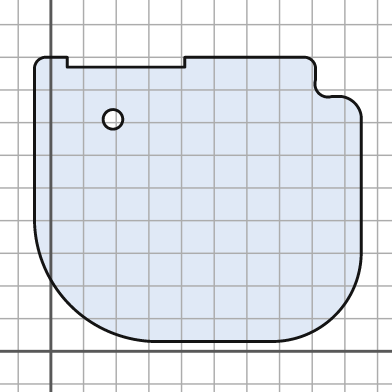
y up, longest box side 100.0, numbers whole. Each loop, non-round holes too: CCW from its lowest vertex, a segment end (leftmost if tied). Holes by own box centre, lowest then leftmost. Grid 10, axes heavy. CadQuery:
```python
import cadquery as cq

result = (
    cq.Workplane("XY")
    .moveTo(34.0, 3.0)
    .lineTo(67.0, 3.0)
    .threePointArc((87.0, 11.0), (95.0, 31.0))
    .lineTo(95.0, 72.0)
    .threePointArc((93.0, 76.0), (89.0, 78.0))
    .lineTo(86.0, 78.0)
    .threePointArc((82.0, 79.0), (81.0, 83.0))
    .lineTo(81.0, 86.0)
    .threePointArc((80.0, 89.0), (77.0, 90.0))
    .lineTo(41.0, 90.0)
    .lineTo(41.0, 87.0)
    .lineTo(5.0, 87.0)
    .lineTo(5.0, 90.0)
    .lineTo(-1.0, 90.0)
    .threePointArc((-4.0, 89.0), (-5.0, 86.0))
    .lineTo(-5.0, 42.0)
    .threePointArc((6.0, 14.0), (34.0, 3.0))
    .close()
    .moveTo(19.0, 71.0)
    .circle(3.0)
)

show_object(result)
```